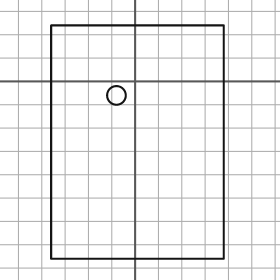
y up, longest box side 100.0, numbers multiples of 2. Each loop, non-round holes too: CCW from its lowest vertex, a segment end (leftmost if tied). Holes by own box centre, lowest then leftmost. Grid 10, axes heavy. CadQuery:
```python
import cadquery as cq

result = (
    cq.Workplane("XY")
    .moveTo(-36.0, -76.0)
    .lineTo(38.0, -76.0)
    .lineTo(38.0, 24.0)
    .lineTo(-36.0, 24.0)
    .close()
    .moveTo(-8.0, -6.0)
    .circle(4.0)
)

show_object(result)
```